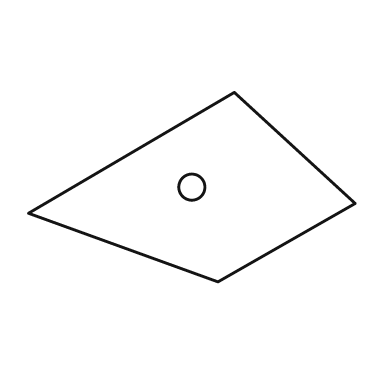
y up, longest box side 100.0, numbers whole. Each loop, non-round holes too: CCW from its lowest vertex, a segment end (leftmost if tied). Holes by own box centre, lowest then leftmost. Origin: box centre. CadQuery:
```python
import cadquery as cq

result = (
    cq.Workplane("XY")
    .moveTo(8.0, -29.0)
    .lineTo(50.0, -5.0)
    .lineTo(13.0, 29.0)
    .lineTo(-50.0, -8.0)
    .close()
    .moveTo(0.0, 0.0)
    .circle(4.0)
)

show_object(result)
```